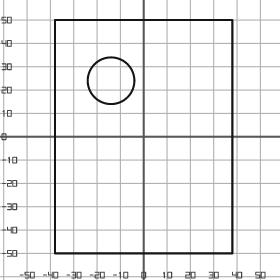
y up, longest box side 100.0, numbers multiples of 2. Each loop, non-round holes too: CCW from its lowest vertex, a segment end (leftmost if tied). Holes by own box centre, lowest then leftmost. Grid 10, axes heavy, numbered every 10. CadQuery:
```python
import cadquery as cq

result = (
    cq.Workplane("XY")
    .moveTo(-38.0, -50.0)
    .lineTo(38.0, -50.0)
    .lineTo(38.0, 50.0)
    .lineTo(-38.0, 50.0)
    .close()
    .moveTo(-14.0, 24.0)
    .circle(10.0)
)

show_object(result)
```